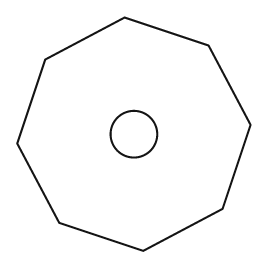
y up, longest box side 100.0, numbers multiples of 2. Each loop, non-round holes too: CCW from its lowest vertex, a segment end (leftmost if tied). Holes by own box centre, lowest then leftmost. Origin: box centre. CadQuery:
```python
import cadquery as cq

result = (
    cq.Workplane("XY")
    .moveTo(4.0, -50.0)
    .lineTo(38.0, -32.0)
    .lineTo(50.0, 4.0)
    .lineTo(32.0, 38.0)
    .lineTo(-4.0, 50.0)
    .lineTo(-38.0, 32.0)
    .lineTo(-50.0, -4.0)
    .lineTo(-32.0, -38.0)
    .close()
    .moveTo(0.0, 0.0)
    .circle(10.0)
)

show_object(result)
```